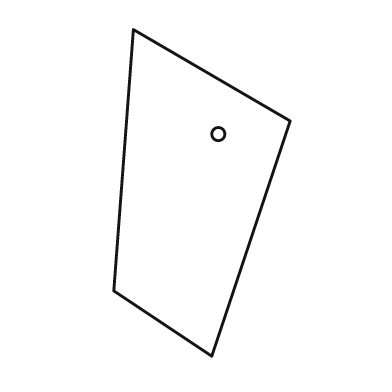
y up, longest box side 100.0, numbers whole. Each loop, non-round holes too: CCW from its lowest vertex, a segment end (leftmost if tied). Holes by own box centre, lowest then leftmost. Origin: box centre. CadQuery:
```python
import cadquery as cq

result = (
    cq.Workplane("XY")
    .moveTo(3.0, -50.0)
    .lineTo(27.0, 22.0)
    .lineTo(-21.0, 50.0)
    .lineTo(-27.0, -30.0)
    .close()
    .moveTo(5.0, 18.0)
    .circle(2.0)
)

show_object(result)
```